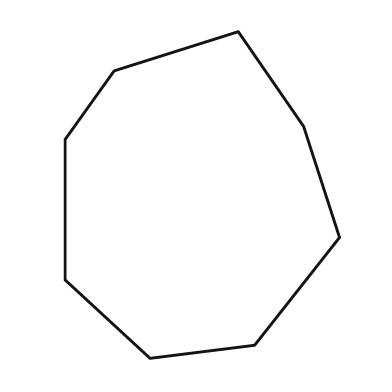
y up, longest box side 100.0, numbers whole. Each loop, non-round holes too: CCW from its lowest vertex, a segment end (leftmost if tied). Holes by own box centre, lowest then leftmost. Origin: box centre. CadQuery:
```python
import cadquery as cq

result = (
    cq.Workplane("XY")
    .moveTo(-16.0, -50.0)
    .lineTo(16.0, -46.0)
    .lineTo(42.0, -13.0)
    .lineTo(31.0, 21.0)
    .lineTo(11.0, 50.0)
    .lineTo(-27.0, 38.0)
    .lineTo(-42.0, 17.0)
    .lineTo(-42.0, -26.0)
    .close()
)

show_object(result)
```